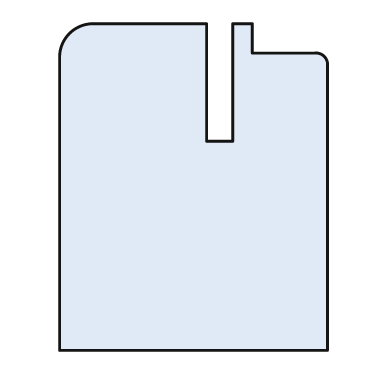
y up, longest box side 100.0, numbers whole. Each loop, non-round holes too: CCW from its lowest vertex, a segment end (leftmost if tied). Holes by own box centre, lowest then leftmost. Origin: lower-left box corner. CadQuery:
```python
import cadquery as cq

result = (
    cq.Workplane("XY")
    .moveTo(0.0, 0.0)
    .lineTo(82.0, 0.0)
    .lineTo(82.0, 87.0)
    .threePointArc((81.0, 90.0), (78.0, 91.0))
    .lineTo(59.0, 91.0)
    .lineTo(59.0, 100.0)
    .lineTo(53.0, 100.0)
    .lineTo(53.0, 64.0)
    .lineTo(45.0, 64.0)
    .lineTo(45.0, 100.0)
    .lineTo(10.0, 100.0)
    .threePointArc((3.0, 97.0), (0.0, 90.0))
    .close()
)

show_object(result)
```